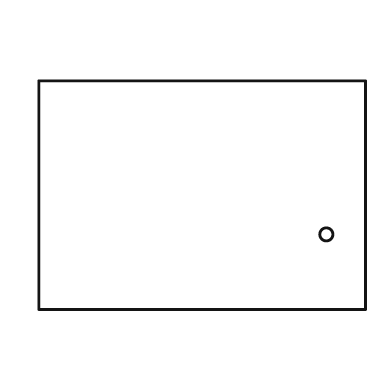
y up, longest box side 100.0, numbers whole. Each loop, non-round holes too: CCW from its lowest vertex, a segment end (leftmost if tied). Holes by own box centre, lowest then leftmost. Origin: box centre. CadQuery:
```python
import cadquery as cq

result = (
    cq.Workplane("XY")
    .moveTo(-50.0, -35.0)
    .lineTo(50.0, -35.0)
    .lineTo(50.0, 35.0)
    .lineTo(-50.0, 35.0)
    .close()
    .moveTo(38.0, -12.0)
    .circle(2.0)
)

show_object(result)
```